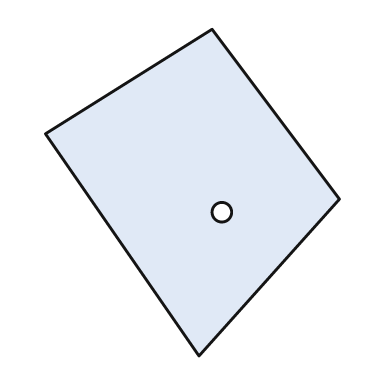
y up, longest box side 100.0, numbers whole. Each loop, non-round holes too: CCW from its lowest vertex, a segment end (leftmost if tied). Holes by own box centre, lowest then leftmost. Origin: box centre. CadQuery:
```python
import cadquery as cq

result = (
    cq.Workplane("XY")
    .moveTo(2.0, -50.0)
    .lineTo(45.0, -2.0)
    .lineTo(6.0, 50.0)
    .lineTo(-45.0, 18.0)
    .close()
    .moveTo(9.0, -6.0)
    .circle(3.0)
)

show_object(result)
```